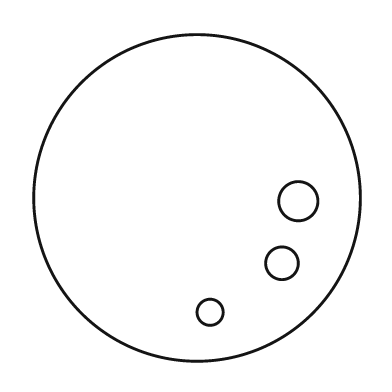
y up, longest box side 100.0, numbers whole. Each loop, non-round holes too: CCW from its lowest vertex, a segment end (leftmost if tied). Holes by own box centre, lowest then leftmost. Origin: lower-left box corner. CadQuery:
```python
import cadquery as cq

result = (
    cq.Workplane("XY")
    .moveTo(50.0, 50.0)
    .circle(50.0)
    .moveTo(54.0, 15.0)
    .circle(4.0)
    .moveTo(76.0, 30.0)
    .circle(5.0)
    .moveTo(81.0, 49.0)
    .circle(6.0)
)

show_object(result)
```